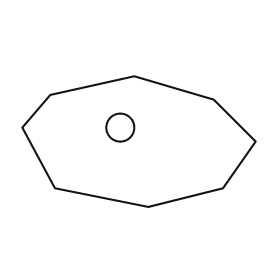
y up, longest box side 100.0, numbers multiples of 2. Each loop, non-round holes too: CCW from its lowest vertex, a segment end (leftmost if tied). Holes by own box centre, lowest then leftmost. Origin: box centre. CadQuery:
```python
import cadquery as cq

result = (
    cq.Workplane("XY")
    .moveTo(4.0, -28.0)
    .lineTo(36.0, -20.0)
    .lineTo(50.0, 0.0)
    .lineTo(32.0, 18.0)
    .lineTo(-2.0, 28.0)
    .lineTo(-38.0, 20.0)
    .lineTo(-50.0, 6.0)
    .lineTo(-36.0, -20.0)
    .close()
    .moveTo(-8.0, 6.0)
    .circle(6.0)
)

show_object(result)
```